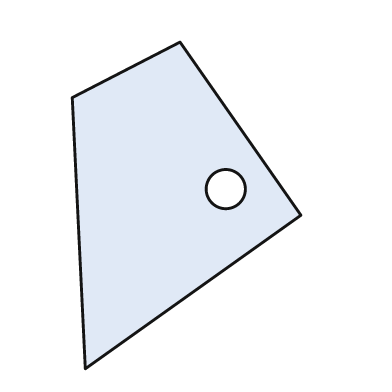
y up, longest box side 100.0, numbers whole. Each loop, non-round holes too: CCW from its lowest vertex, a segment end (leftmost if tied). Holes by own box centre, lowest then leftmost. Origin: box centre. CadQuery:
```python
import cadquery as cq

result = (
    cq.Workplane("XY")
    .moveTo(-31.0, -50.0)
    .lineTo(35.0, -3.0)
    .lineTo(-2.0, 50.0)
    .lineTo(-35.0, 33.0)
    .close()
    .moveTo(12.0, 5.0)
    .circle(6.0)
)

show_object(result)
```